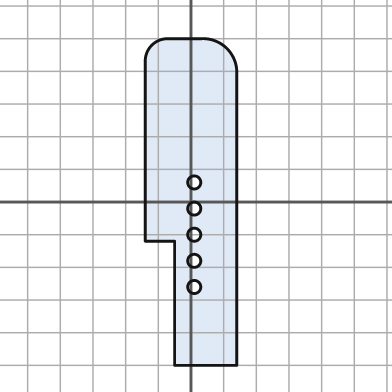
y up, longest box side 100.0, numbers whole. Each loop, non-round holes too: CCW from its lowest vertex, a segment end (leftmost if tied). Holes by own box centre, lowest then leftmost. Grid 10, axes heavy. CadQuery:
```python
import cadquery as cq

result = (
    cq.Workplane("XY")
    .moveTo(-5.0, -50.0)
    .lineTo(14.0, -50.0)
    .lineTo(14.0, 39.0)
    .threePointArc((11.0, 47.0), (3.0, 50.0))
    .lineTo(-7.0, 50.0)
    .threePointArc((-12.0, 48.0), (-14.0, 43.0))
    .lineTo(-14.0, -12.0)
    .lineTo(-5.0, -12.0)
    .close()
    .moveTo(1.0, -26.0)
    .circle(2.0)
    .moveTo(1.0, -18.0)
    .circle(2.0)
    .moveTo(1.0, -10.0)
    .circle(2.0)
    .moveTo(1.0, -2.0)
    .circle(2.0)
    .moveTo(1.0, 6.0)
    .circle(2.0)
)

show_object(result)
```